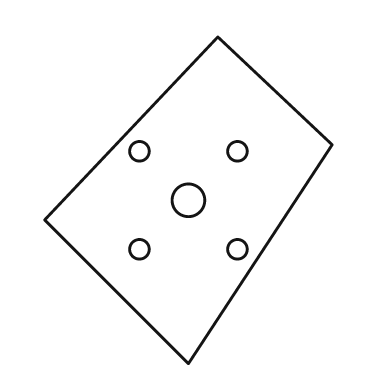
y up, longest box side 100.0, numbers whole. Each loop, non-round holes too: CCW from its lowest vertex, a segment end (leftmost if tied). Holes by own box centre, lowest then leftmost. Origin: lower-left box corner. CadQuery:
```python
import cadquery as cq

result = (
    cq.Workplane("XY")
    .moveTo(44.0, 0.0)
    .lineTo(88.0, 67.0)
    .lineTo(53.0, 100.0)
    .lineTo(0.0, 44.0)
    .close()
    .moveTo(29.0, 35.0)
    .circle(3.0)
    .moveTo(59.0, 35.0)
    .circle(3.0)
    .moveTo(44.0, 50.0)
    .circle(5.0)
    .moveTo(29.0, 65.0)
    .circle(3.0)
    .moveTo(59.0, 65.0)
    .circle(3.0)
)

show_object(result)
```